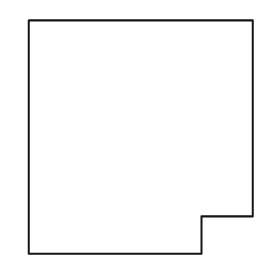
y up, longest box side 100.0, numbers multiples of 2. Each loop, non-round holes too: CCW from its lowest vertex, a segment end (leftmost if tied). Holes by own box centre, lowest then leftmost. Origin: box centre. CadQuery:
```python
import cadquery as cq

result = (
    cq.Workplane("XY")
    .moveTo(-48.0, -50.0)
    .lineTo(26.0, -50.0)
    .lineTo(26.0, -34.0)
    .lineTo(48.0, -34.0)
    .lineTo(48.0, 50.0)
    .lineTo(-48.0, 50.0)
    .close()
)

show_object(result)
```